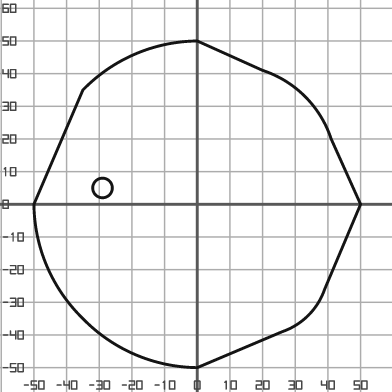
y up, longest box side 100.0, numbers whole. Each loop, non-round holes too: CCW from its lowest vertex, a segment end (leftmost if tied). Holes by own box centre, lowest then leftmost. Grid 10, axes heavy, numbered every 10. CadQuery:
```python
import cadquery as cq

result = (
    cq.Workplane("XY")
    .moveTo(0.0, -50.0)
    .lineTo(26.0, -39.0)
    .threePointArc((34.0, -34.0), (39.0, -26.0))
    .lineTo(50.0, 0.0)
    .lineTo(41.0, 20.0)
    .threePointArc((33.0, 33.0), (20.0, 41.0))
    .lineTo(0.0, 50.0)
    .threePointArc((-19.0, 46.0), (-35.0, 35.0))
    .lineTo(-50.0, 0.0)
    .threePointArc((-46.0, -19.0), (-35.0, -35.0))
    .threePointArc((-19.0, -46.0), (0.0, -50.0))
    .close()
    .moveTo(-29.0, 5.0)
    .circle(3.0)
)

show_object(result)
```